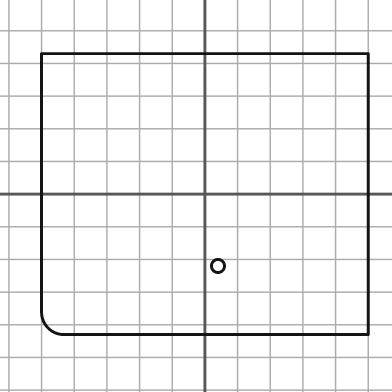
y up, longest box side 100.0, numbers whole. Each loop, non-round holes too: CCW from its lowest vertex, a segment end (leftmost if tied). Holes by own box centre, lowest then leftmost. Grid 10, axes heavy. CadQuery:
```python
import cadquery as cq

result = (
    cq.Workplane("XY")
    .moveTo(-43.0, -43.0)
    .lineTo(50.0, -43.0)
    .lineTo(50.0, 43.0)
    .lineTo(-50.0, 43.0)
    .lineTo(-50.0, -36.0)
    .threePointArc((-48.0, -41.0), (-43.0, -43.0))
    .close()
    .moveTo(4.0, -22.0)
    .circle(2.0)
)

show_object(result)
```